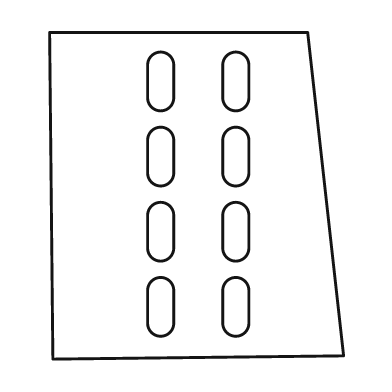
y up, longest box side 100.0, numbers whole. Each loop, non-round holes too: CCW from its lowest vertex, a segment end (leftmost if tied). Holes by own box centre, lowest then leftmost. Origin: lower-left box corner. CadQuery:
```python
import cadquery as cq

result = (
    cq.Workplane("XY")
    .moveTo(1.0, 0.0)
    .lineTo(90.0, 1.0)
    .lineTo(79.0, 100.0)
    .lineTo(0.0, 100.0)
    .close()
    .moveTo(30.0, 11.0)
    .threePointArc((34.0, 7.0), (38.0, 11.0))
    .lineTo(38.0, 21.0)
    .threePointArc((34.0, 25.0), (30.0, 21.0))
    .close()
    .moveTo(53.0, 11.0)
    .threePointArc((57.0, 7.0), (61.0, 11.0))
    .lineTo(61.0, 21.0)
    .threePointArc((57.0, 25.0), (53.0, 21.0))
    .close()
    .moveTo(30.0, 34.0)
    .threePointArc((34.0, 30.0), (38.0, 34.0))
    .lineTo(38.0, 44.0)
    .threePointArc((34.0, 48.0), (30.0, 44.0))
    .close()
    .moveTo(53.0, 34.0)
    .threePointArc((57.0, 30.0), (61.0, 34.0))
    .lineTo(61.0, 44.0)
    .threePointArc((57.0, 48.0), (53.0, 44.0))
    .close()
    .moveTo(30.0, 57.0)
    .threePointArc((34.0, 53.0), (38.0, 57.0))
    .lineTo(38.0, 67.0)
    .threePointArc((34.0, 71.0), (30.0, 67.0))
    .close()
    .moveTo(53.0, 57.0)
    .threePointArc((57.0, 53.0), (61.0, 57.0))
    .lineTo(61.0, 67.0)
    .threePointArc((57.0, 71.0), (53.0, 67.0))
    .close()
    .moveTo(30.0, 80.0)
    .threePointArc((34.0, 76.0), (38.0, 80.0))
    .lineTo(38.0, 90.0)
    .threePointArc((34.0, 94.0), (30.0, 90.0))
    .close()
    .moveTo(53.0, 80.0)
    .threePointArc((57.0, 76.0), (61.0, 80.0))
    .lineTo(61.0, 90.0)
    .threePointArc((57.0, 94.0), (53.0, 90.0))
    .close()
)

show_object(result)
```